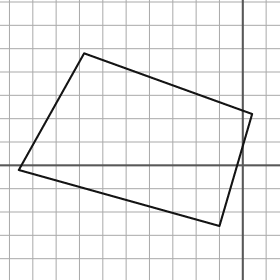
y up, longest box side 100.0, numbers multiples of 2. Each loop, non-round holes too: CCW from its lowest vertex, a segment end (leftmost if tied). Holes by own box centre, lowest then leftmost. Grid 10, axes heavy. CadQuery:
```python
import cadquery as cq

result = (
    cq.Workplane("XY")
    .moveTo(-10.0, -26.0)
    .lineTo(4.0, 22.0)
    .lineTo(-68.0, 48.0)
    .lineTo(-96.0, -2.0)
    .close()
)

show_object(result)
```